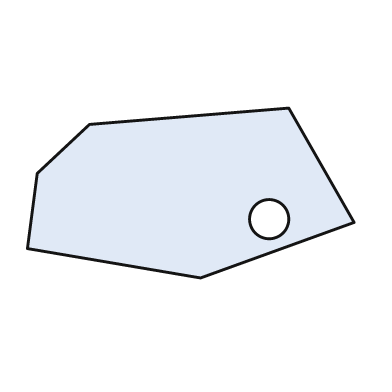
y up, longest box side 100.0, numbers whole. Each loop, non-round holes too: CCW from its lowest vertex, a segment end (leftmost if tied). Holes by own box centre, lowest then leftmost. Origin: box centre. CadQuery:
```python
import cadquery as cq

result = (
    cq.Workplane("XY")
    .moveTo(3.0, -26.0)
    .lineTo(50.0, -9.0)
    .lineTo(30.0, 26.0)
    .lineTo(-31.0, 21.0)
    .lineTo(-47.0, 6.0)
    .lineTo(-50.0, -17.0)
    .close()
    .moveTo(24.0, -8.0)
    .circle(6.0)
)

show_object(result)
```